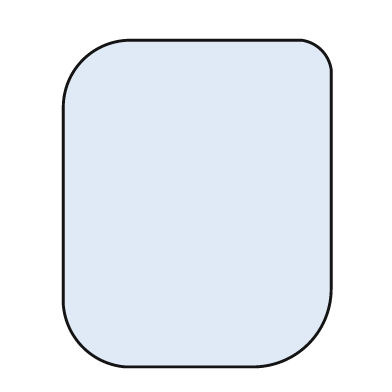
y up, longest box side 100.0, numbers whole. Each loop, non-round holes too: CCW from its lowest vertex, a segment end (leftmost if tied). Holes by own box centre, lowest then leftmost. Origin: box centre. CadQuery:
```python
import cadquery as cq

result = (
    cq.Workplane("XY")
    .moveTo(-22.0, -50.0)
    .lineTo(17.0, -50.0)
    .threePointArc((34.0, -43.0), (41.0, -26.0))
    .lineTo(41.0, 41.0)
    .threePointArc((38.0, 47.0), (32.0, 50.0))
    .lineTo(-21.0, 50.0)
    .threePointArc((-35.0, 44.0), (-41.0, 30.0))
    .lineTo(-41.0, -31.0)
    .threePointArc((-35.0, -44.0), (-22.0, -50.0))
    .close()
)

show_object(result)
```